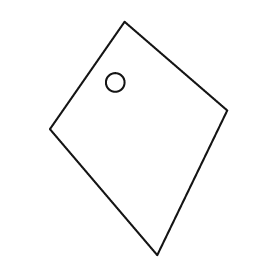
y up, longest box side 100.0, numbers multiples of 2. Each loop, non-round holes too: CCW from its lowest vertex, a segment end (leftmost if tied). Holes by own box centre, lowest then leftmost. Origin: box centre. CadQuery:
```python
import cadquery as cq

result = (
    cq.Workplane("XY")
    .moveTo(8.0, -50.0)
    .lineTo(38.0, 12.0)
    .lineTo(-6.0, 50.0)
    .lineTo(-38.0, 4.0)
    .close()
    .moveTo(-10.0, 24.0)
    .circle(4.0)
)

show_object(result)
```